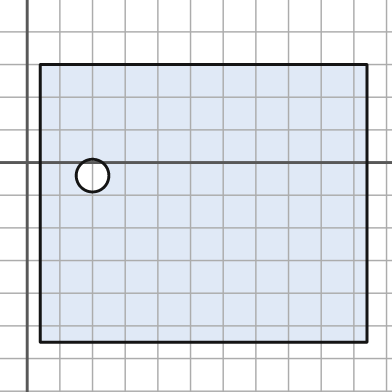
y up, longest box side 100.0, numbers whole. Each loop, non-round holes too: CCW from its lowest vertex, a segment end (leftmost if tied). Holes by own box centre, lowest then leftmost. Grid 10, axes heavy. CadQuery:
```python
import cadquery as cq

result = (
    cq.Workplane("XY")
    .moveTo(4.0, -55.0)
    .lineTo(104.0, -55.0)
    .lineTo(104.0, 30.0)
    .lineTo(4.0, 30.0)
    .close()
    .moveTo(20.0, -4.0)
    .circle(5.0)
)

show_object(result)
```